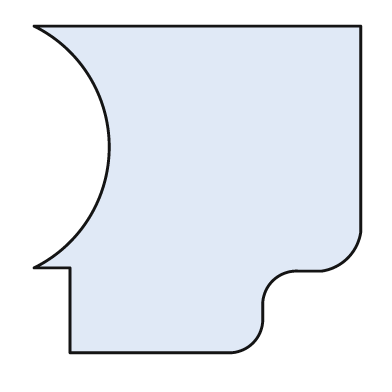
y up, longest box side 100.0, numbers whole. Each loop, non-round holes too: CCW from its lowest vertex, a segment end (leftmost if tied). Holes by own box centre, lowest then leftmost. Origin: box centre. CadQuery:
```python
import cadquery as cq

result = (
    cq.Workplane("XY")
    .moveTo(-39.0, -50.0)
    .lineTo(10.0, -50.0)
    .threePointArc((17.0, -47.0), (20.0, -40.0))
    .lineTo(20.0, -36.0)
    .threePointArc((23.0, -28.0), (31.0, -25.0))
    .lineTo(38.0, -25.0)
    .threePointArc((46.0, -21.0), (50.0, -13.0))
    .lineTo(50.0, 50.0)
    .lineTo(-50.0, 50.0)
    .threePointArc((-27.0, 13.0), (-50.0, -24.0))
    .lineTo(-39.0, -24.0)
    .close()
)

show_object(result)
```